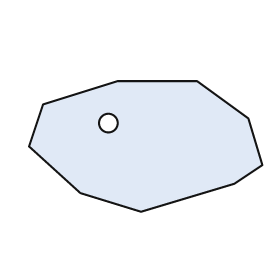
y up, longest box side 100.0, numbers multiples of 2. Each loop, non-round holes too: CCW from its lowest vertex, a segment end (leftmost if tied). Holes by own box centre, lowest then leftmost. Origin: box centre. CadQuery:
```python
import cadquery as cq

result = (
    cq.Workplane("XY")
    .moveTo(-2.0, -28.0)
    .lineTo(38.0, -16.0)
    .lineTo(50.0, -8.0)
    .lineTo(44.0, 12.0)
    .lineTo(22.0, 28.0)
    .lineTo(-12.0, 28.0)
    .lineTo(-44.0, 18.0)
    .lineTo(-50.0, 0.0)
    .lineTo(-28.0, -20.0)
    .close()
    .moveTo(-16.0, 10.0)
    .circle(4.0)
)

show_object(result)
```